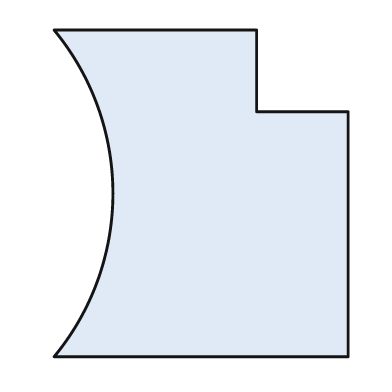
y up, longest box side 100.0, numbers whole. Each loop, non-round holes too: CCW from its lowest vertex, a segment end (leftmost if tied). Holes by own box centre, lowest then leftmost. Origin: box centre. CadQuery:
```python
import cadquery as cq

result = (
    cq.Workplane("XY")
    .moveTo(-45.0, -50.0)
    .lineTo(45.0, -50.0)
    .lineTo(45.0, 25.0)
    .lineTo(17.0, 25.0)
    .lineTo(17.0, 50.0)
    .lineTo(-45.0, 50.0)
    .threePointArc((-27.0, 0.0), (-45.0, -50.0))
    .close()
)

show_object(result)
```